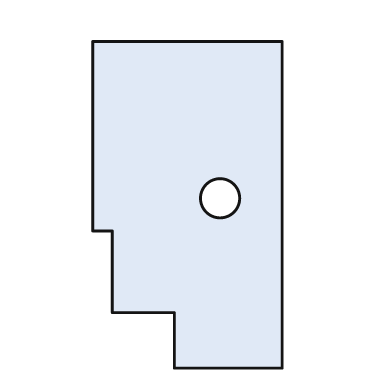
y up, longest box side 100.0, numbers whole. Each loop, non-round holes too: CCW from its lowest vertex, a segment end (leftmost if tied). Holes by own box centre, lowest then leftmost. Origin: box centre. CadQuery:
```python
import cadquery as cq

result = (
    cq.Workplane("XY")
    .moveTo(-4.0, -50.0)
    .lineTo(29.0, -50.0)
    .lineTo(29.0, 50.0)
    .lineTo(-29.0, 50.0)
    .lineTo(-29.0, -8.0)
    .lineTo(-23.0, -8.0)
    .lineTo(-23.0, -33.0)
    .lineTo(-4.0, -33.0)
    .close()
    .moveTo(10.0, 2.0)
    .circle(6.0)
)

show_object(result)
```